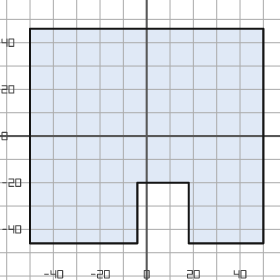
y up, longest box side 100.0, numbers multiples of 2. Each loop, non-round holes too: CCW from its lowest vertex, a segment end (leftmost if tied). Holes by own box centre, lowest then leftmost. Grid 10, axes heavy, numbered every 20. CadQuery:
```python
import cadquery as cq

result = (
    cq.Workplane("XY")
    .moveTo(-50.0, -46.0)
    .lineTo(-4.0, -46.0)
    .lineTo(-4.0, -20.0)
    .lineTo(18.0, -20.0)
    .lineTo(18.0, -46.0)
    .lineTo(50.0, -46.0)
    .lineTo(50.0, 46.0)
    .lineTo(-50.0, 46.0)
    .close()
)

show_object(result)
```